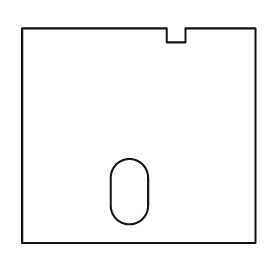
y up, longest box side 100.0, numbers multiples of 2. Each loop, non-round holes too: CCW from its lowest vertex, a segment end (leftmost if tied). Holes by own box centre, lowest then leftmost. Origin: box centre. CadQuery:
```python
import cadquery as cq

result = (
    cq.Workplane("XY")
    .moveTo(-50.0, -46.0)
    .lineTo(50.0, -46.0)
    .lineTo(50.0, 46.0)
    .lineTo(20.0, 46.0)
    .lineTo(20.0, 40.0)
    .lineTo(12.0, 40.0)
    .lineTo(12.0, 46.0)
    .lineTo(-50.0, 46.0)
    .close()
    .moveTo(-12.0, -30.0)
    .threePointArc((-4.0, -38.0), (4.0, -30.0))
    .lineTo(4.0, -18.0)
    .threePointArc((-4.0, -10.0), (-12.0, -18.0))
    .close()
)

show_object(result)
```